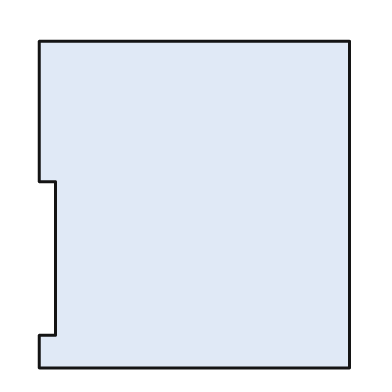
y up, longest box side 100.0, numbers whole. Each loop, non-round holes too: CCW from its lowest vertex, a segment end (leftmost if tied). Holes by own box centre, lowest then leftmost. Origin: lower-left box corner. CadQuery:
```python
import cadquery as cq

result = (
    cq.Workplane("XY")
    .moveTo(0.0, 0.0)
    .lineTo(95.0, 0.0)
    .lineTo(95.0, 100.0)
    .lineTo(0.0, 100.0)
    .lineTo(0.0, 57.0)
    .lineTo(5.0, 57.0)
    .lineTo(5.0, 10.0)
    .lineTo(0.0, 10.0)
    .close()
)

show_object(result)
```